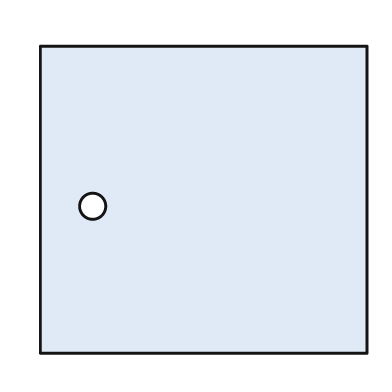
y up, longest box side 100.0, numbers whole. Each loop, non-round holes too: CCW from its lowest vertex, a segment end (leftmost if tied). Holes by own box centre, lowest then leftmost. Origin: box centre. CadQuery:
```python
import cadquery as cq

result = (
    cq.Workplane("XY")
    .moveTo(-50.0, -47.0)
    .lineTo(50.0, -47.0)
    .lineTo(50.0, 47.0)
    .lineTo(-50.0, 47.0)
    .close()
    .moveTo(-34.0, -2.0)
    .circle(4.0)
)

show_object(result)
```